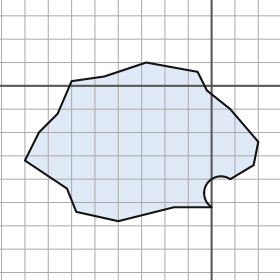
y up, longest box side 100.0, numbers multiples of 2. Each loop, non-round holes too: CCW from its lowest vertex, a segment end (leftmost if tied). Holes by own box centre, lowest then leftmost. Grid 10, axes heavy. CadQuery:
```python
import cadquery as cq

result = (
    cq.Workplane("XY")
    .moveTo(-40.0, -58.0)
    .lineTo(-16.0, -52.0)
    .lineTo(0.0, -52.0)
    .threePointArc((-2.0, -42.0), (8.0, -40.0))
    .lineTo(18.0, -34.0)
    .lineTo(20.0, -24.0)
    .lineTo(8.0, -10.0)
    .lineTo(-2.0, -2.0)
    .lineTo(-6.0, 6.0)
    .lineTo(-28.0, 10.0)
    .lineTo(-46.0, 4.0)
    .lineTo(-60.0, 2.0)
    .lineTo(-66.0, -12.0)
    .lineTo(-74.0, -20.0)
    .lineTo(-80.0, -32.0)
    .lineTo(-62.0, -44.0)
    .lineTo(-58.0, -54.0)
    .close()
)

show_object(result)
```